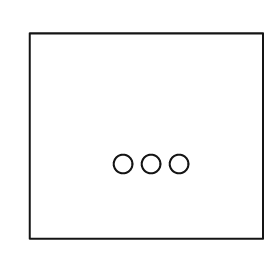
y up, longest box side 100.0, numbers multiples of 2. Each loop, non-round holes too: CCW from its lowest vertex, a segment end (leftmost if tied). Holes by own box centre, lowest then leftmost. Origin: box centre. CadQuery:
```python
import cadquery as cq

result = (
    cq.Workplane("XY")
    .moveTo(-50.0, -44.0)
    .lineTo(50.0, -44.0)
    .lineTo(50.0, 44.0)
    .lineTo(-50.0, 44.0)
    .close()
    .moveTo(-10.0, -12.0)
    .circle(4.0)
    .moveTo(2.0, -12.0)
    .circle(4.0)
    .moveTo(14.0, -12.0)
    .circle(4.0)
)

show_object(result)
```